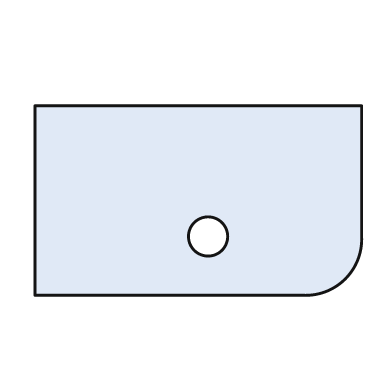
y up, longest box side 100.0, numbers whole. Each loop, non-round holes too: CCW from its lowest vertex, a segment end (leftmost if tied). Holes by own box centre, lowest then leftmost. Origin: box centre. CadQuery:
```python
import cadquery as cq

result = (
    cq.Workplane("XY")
    .moveTo(-50.0, -29.0)
    .lineTo(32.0, -29.0)
    .threePointArc((45.0, -24.0), (50.0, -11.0))
    .lineTo(50.0, 29.0)
    .lineTo(-50.0, 29.0)
    .close()
    .moveTo(3.0, -11.0)
    .circle(6.0)
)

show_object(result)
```